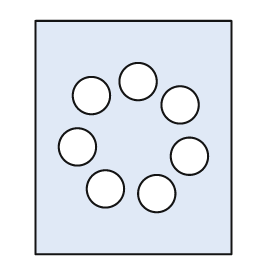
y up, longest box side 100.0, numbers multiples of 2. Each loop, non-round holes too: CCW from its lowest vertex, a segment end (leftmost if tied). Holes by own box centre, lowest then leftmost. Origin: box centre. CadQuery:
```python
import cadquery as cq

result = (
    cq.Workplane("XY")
    .moveTo(-42.0, -50.0)
    .lineTo(42.0, -50.0)
    .lineTo(42.0, 50.0)
    .lineTo(-42.0, 50.0)
    .close()
    .moveTo(10.0, -24.0)
    .circle(8.0)
    .moveTo(-12.0, -22.0)
    .circle(8.0)
    .moveTo(24.0, -8.0)
    .circle(8.0)
    .moveTo(-24.0, -4.0)
    .circle(8.0)
    .moveTo(20.0, 14.0)
    .circle(8.0)
    .moveTo(-18.0, 18.0)
    .circle(8.0)
    .moveTo(2.0, 24.0)
    .circle(8.0)
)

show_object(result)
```